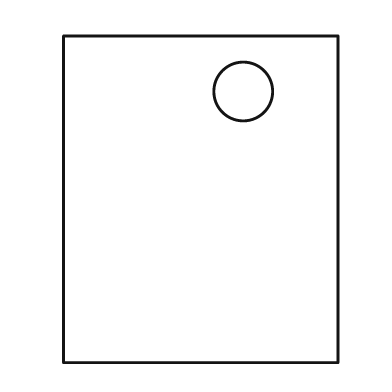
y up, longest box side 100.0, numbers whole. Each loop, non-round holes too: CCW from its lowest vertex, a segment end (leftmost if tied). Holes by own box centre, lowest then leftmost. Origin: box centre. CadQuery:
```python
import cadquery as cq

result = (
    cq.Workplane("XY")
    .moveTo(-42.0, -50.0)
    .lineTo(42.0, -50.0)
    .lineTo(42.0, 50.0)
    .lineTo(-42.0, 50.0)
    .close()
    .moveTo(13.0, 33.0)
    .circle(9.0)
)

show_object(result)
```